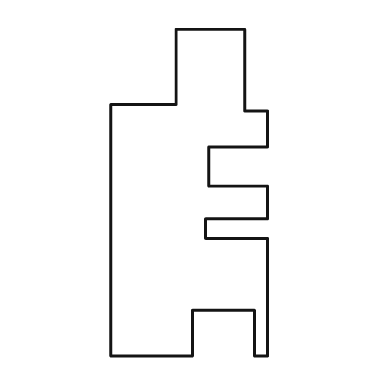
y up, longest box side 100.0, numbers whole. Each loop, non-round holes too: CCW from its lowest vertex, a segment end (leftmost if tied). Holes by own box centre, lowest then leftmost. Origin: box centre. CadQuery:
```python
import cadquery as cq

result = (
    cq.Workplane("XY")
    .moveTo(-24.0, -50.0)
    .lineTo(1.0, -50.0)
    .lineTo(1.0, -36.0)
    .lineTo(20.0, -36.0)
    .lineTo(20.0, -50.0)
    .lineTo(24.0, -50.0)
    .lineTo(24.0, -14.0)
    .lineTo(5.0, -14.0)
    .lineTo(5.0, -8.0)
    .lineTo(24.0, -8.0)
    .lineTo(24.0, 2.0)
    .lineTo(6.0, 2.0)
    .lineTo(6.0, 14.0)
    .lineTo(24.0, 14.0)
    .lineTo(24.0, 25.0)
    .lineTo(17.0, 25.0)
    .lineTo(17.0, 50.0)
    .lineTo(-4.0, 50.0)
    .lineTo(-4.0, 27.0)
    .lineTo(-24.0, 27.0)
    .close()
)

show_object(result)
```